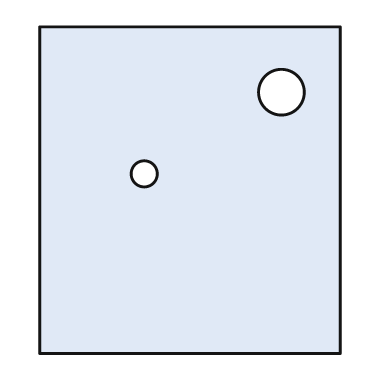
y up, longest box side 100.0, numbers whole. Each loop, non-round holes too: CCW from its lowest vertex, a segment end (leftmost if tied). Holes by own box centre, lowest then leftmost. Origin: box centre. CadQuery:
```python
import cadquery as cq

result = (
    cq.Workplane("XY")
    .moveTo(-46.0, -50.0)
    .lineTo(46.0, -50.0)
    .lineTo(46.0, 50.0)
    .lineTo(-46.0, 50.0)
    .close()
    .moveTo(-14.0, 5.0)
    .circle(4.0)
    .moveTo(28.0, 30.0)
    .circle(7.0)
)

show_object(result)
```